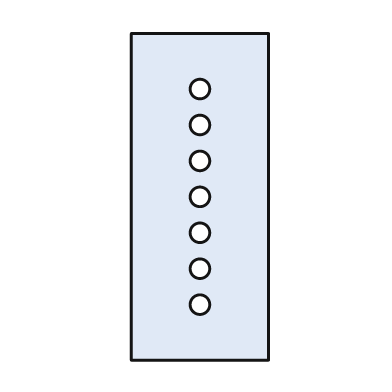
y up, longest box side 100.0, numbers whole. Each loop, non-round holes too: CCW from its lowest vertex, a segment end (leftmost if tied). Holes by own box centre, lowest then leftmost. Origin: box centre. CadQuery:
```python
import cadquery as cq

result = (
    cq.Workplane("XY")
    .moveTo(-21.0, -50.0)
    .lineTo(21.0, -50.0)
    .lineTo(21.0, 50.0)
    .lineTo(-21.0, 50.0)
    .close()
    .moveTo(0.0, -33.0)
    .circle(3.0)
    .moveTo(0.0, -22.0)
    .circle(3.0)
    .moveTo(0.0, -11.0)
    .circle(3.0)
    .moveTo(0.0, 0.0)
    .circle(3.0)
    .moveTo(0.0, 11.0)
    .circle(3.0)
    .moveTo(0.0, 22.0)
    .circle(3.0)
    .moveTo(0.0, 33.0)
    .circle(3.0)
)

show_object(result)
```